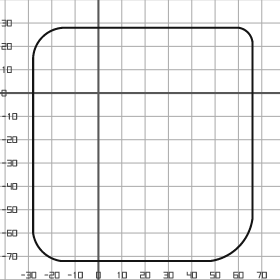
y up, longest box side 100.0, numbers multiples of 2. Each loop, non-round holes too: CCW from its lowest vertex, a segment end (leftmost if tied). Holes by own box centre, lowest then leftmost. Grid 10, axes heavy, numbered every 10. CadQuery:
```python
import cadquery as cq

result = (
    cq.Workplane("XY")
    .moveTo(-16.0, -72.0)
    .lineTo(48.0, -72.0)
    .threePointArc((60.0, -66.0), (66.0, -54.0))
    .lineTo(66.0, 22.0)
    .threePointArc((64.0, 26.0), (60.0, 28.0))
    .lineTo(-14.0, 28.0)
    .threePointArc((-24.0, 24.0), (-28.0, 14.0))
    .lineTo(-28.0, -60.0)
    .threePointArc((-24.0, -68.0), (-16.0, -72.0))
    .close()
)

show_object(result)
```